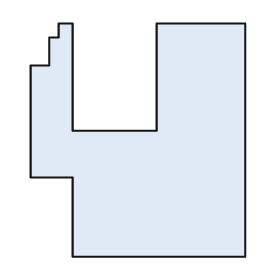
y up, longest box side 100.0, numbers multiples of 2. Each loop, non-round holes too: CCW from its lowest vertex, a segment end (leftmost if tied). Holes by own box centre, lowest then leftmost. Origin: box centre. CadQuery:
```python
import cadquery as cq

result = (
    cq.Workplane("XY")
    .moveTo(-28.0, -50.0)
    .lineTo(46.0, -50.0)
    .lineTo(46.0, 50.0)
    .lineTo(8.0, 50.0)
    .lineTo(8.0, 4.0)
    .lineTo(-28.0, 4.0)
    .lineTo(-28.0, 50.0)
    .lineTo(-34.0, 50.0)
    .lineTo(-34.0, 44.0)
    .lineTo(-38.0, 44.0)
    .lineTo(-38.0, 32.0)
    .lineTo(-46.0, 32.0)
    .lineTo(-46.0, -16.0)
    .lineTo(-28.0, -16.0)
    .close()
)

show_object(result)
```